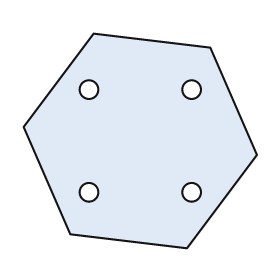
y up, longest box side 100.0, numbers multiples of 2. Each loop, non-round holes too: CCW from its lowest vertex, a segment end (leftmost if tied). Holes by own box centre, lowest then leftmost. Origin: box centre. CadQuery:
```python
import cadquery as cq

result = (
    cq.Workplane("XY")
    .moveTo(20.0, -46.0)
    .lineTo(50.0, -6.0)
    .lineTo(30.0, 40.0)
    .lineTo(-20.0, 46.0)
    .lineTo(-50.0, 6.0)
    .lineTo(-30.0, -40.0)
    .close()
    .moveTo(-22.0, -22.0)
    .circle(4.0)
    .moveTo(22.0, -22.0)
    .circle(4.0)
    .moveTo(-22.0, 22.0)
    .circle(4.0)
    .moveTo(22.0, 22.0)
    .circle(4.0)
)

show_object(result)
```